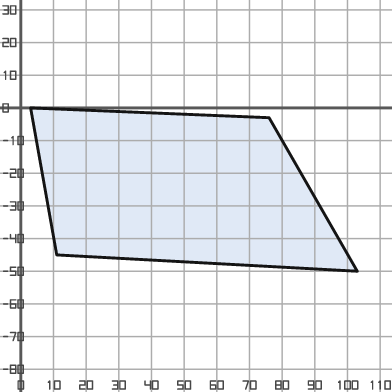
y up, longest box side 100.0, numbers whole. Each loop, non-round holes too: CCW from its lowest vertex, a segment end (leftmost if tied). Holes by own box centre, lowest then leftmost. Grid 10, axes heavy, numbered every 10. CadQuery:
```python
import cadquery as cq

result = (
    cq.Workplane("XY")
    .moveTo(103.0, -50.0)
    .lineTo(76.0, -3.0)
    .lineTo(3.0, 0.0)
    .lineTo(11.0, -45.0)
    .close()
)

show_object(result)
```